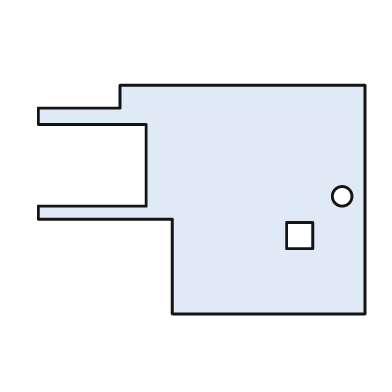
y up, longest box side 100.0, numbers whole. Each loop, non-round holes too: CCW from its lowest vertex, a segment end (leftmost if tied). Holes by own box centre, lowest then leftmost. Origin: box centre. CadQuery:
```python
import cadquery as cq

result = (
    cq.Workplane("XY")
    .moveTo(-9.0, -35.0)
    .lineTo(50.0, -35.0)
    .lineTo(50.0, 35.0)
    .lineTo(-25.0, 35.0)
    .lineTo(-25.0, 28.0)
    .lineTo(-50.0, 28.0)
    .lineTo(-50.0, 23.0)
    .lineTo(-17.0, 23.0)
    .lineTo(-17.0, -2.0)
    .lineTo(-50.0, -2.0)
    .lineTo(-50.0, -6.0)
    .lineTo(-9.0, -6.0)
    .close()
    .moveTo(26.0, -15.0)
    .lineTo(34.0, -15.0)
    .lineTo(34.0, -7.0)
    .lineTo(26.0, -7.0)
    .close()
    .moveTo(43.0, 1.0)
    .circle(3.0)
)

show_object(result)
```